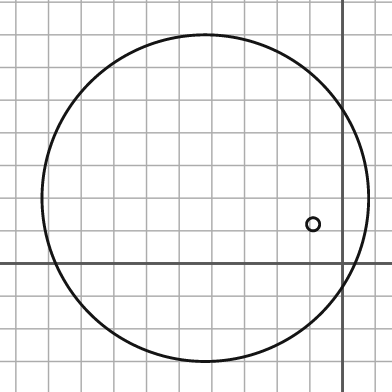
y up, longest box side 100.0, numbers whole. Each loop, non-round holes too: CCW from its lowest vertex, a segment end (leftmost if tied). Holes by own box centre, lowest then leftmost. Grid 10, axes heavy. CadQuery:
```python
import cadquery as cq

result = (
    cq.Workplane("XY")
    .moveTo(-42.0, 20.0)
    .circle(50.0)
    .moveTo(-9.0, 12.0)
    .circle(2.0)
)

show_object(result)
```